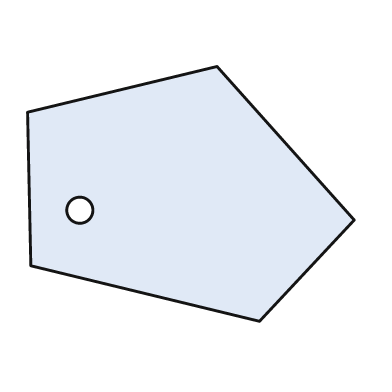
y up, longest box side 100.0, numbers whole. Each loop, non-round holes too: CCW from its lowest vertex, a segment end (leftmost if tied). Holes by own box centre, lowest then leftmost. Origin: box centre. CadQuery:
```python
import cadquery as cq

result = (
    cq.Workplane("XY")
    .moveTo(21.0, -39.0)
    .lineTo(50.0, -8.0)
    .lineTo(8.0, 39.0)
    .lineTo(-50.0, 25.0)
    .lineTo(-49.0, -22.0)
    .close()
    .moveTo(-34.0, -5.0)
    .circle(4.0)
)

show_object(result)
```